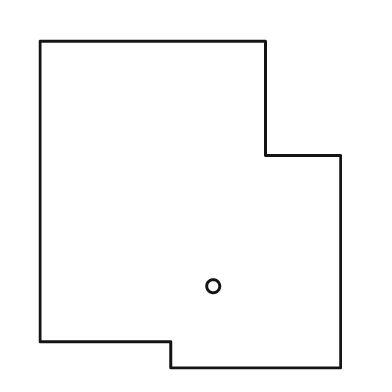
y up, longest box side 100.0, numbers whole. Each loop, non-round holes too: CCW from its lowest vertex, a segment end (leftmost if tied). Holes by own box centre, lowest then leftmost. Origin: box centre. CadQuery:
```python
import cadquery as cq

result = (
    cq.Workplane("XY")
    .moveTo(-6.0, -50.0)
    .lineTo(46.0, -50.0)
    .lineTo(46.0, 15.0)
    .lineTo(23.0, 15.0)
    .lineTo(23.0, 50.0)
    .lineTo(-46.0, 50.0)
    .lineTo(-46.0, -42.0)
    .lineTo(-6.0, -42.0)
    .close()
    .moveTo(7.0, -25.0)
    .circle(2.0)
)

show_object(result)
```